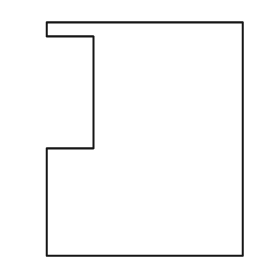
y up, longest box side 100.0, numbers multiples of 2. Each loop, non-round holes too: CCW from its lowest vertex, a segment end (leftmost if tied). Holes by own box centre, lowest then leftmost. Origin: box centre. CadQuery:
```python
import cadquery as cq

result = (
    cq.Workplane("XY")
    .moveTo(-42.0, -50.0)
    .lineTo(42.0, -50.0)
    .lineTo(42.0, 50.0)
    .lineTo(-42.0, 50.0)
    .lineTo(-42.0, 44.0)
    .lineTo(-22.0, 44.0)
    .lineTo(-22.0, -4.0)
    .lineTo(-42.0, -4.0)
    .close()
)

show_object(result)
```